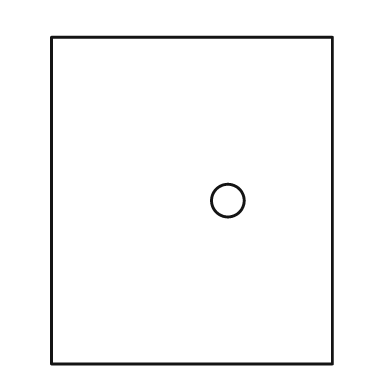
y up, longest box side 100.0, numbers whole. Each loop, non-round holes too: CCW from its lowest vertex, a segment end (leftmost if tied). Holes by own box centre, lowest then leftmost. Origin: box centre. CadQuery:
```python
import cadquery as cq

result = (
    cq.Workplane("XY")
    .moveTo(-43.0, -50.0)
    .lineTo(43.0, -50.0)
    .lineTo(43.0, 50.0)
    .lineTo(-43.0, 50.0)
    .close()
    .moveTo(11.0, 0.0)
    .circle(5.0)
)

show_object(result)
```